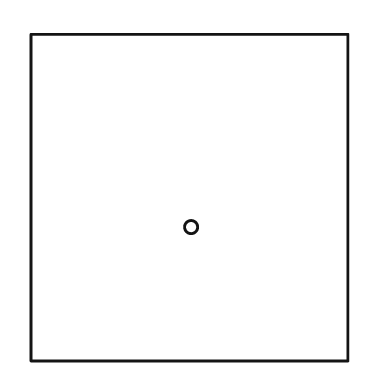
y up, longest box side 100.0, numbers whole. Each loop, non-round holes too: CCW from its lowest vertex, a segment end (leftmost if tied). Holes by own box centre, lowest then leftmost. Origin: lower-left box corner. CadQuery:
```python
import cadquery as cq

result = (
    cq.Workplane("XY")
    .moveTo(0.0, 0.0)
    .lineTo(97.0, 0.0)
    .lineTo(97.0, 100.0)
    .lineTo(0.0, 100.0)
    .close()
    .moveTo(49.0, 41.0)
    .circle(2.0)
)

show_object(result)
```